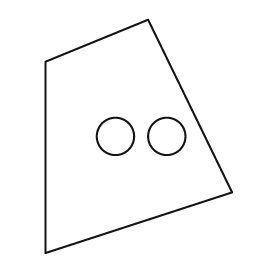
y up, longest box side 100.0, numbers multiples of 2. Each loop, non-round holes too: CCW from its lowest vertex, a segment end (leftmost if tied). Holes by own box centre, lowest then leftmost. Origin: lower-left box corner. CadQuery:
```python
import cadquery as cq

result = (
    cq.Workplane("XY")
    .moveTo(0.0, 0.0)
    .lineTo(80.0, 26.0)
    .lineTo(44.0, 100.0)
    .lineTo(0.0, 82.0)
    .close()
    .moveTo(30.0, 50.0)
    .circle(8.0)
    .moveTo(52.0, 50.0)
    .circle(8.0)
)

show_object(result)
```